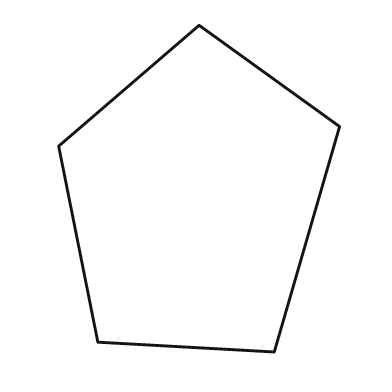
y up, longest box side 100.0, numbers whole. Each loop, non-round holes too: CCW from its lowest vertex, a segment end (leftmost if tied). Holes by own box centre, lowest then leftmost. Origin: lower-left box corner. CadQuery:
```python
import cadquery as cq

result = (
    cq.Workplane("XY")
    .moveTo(66.0, 0.0)
    .lineTo(86.0, 69.0)
    .lineTo(43.0, 100.0)
    .lineTo(0.0, 63.0)
    .lineTo(12.0, 3.0)
    .close()
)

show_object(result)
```